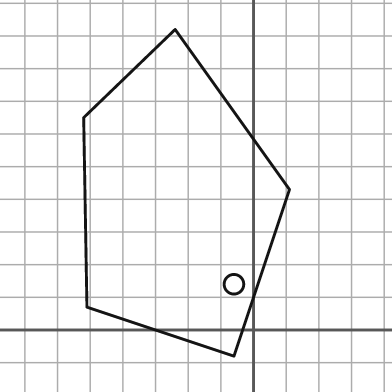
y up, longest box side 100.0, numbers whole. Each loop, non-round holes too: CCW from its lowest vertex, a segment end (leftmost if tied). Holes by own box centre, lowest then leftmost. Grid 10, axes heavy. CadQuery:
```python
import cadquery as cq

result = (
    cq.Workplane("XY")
    .moveTo(-6.0, -8.0)
    .lineTo(11.0, 43.0)
    .lineTo(-24.0, 92.0)
    .lineTo(-52.0, 65.0)
    .lineTo(-51.0, 7.0)
    .close()
    .moveTo(-6.0, 14.0)
    .circle(3.0)
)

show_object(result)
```